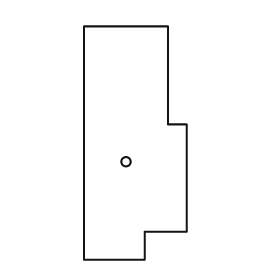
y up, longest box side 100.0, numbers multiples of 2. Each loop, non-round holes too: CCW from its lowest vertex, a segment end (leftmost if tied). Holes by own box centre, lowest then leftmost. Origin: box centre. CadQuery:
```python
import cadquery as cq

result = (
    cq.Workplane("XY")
    .moveTo(-22.0, -50.0)
    .lineTo(4.0, -50.0)
    .lineTo(4.0, -38.0)
    .lineTo(22.0, -38.0)
    .lineTo(22.0, 8.0)
    .lineTo(14.0, 8.0)
    .lineTo(14.0, 50.0)
    .lineTo(-22.0, 50.0)
    .close()
    .moveTo(-4.0, -8.0)
    .circle(2.0)
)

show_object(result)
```